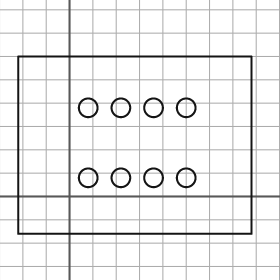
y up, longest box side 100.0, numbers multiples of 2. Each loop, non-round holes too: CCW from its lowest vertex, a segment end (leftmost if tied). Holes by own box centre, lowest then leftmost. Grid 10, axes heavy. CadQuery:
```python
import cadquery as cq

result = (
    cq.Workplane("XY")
    .moveTo(-22.0, -16.0)
    .lineTo(78.0, -16.0)
    .lineTo(78.0, 60.0)
    .lineTo(-22.0, 60.0)
    .close()
    .moveTo(8.0, 8.0)
    .circle(4.0)
    .moveTo(22.0, 8.0)
    .circle(4.0)
    .moveTo(36.0, 8.0)
    .circle(4.0)
    .moveTo(50.0, 8.0)
    .circle(4.0)
    .moveTo(8.0, 38.0)
    .circle(4.0)
    .moveTo(22.0, 38.0)
    .circle(4.0)
    .moveTo(36.0, 38.0)
    .circle(4.0)
    .moveTo(50.0, 38.0)
    .circle(4.0)
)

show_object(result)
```